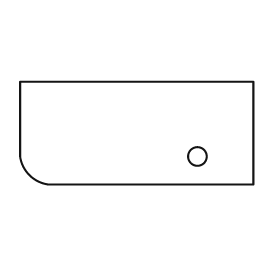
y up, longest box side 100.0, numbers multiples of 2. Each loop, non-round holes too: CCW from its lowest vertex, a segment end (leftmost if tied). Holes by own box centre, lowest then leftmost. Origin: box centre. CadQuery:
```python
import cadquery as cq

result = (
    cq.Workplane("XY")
    .moveTo(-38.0, -22.0)
    .lineTo(50.0, -22.0)
    .lineTo(50.0, 22.0)
    .lineTo(-50.0, 22.0)
    .lineTo(-50.0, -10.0)
    .threePointArc((-46.0, -18.0), (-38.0, -22.0))
    .close()
    .moveTo(26.0, -10.0)
    .circle(4.0)
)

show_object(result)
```